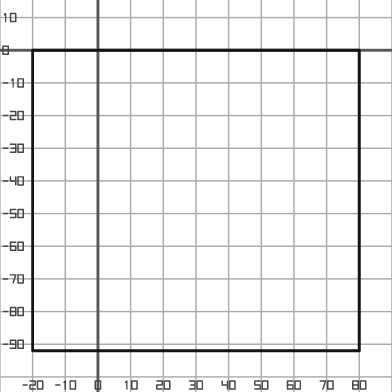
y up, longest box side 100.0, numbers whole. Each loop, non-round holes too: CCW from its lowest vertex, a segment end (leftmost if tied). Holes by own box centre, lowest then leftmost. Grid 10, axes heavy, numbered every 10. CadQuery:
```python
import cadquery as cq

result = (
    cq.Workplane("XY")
    .moveTo(-20.0, -92.0)
    .lineTo(80.0, -92.0)
    .lineTo(80.0, 0.0)
    .lineTo(-20.0, 0.0)
    .close()
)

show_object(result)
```